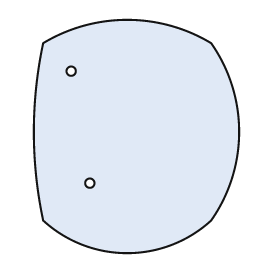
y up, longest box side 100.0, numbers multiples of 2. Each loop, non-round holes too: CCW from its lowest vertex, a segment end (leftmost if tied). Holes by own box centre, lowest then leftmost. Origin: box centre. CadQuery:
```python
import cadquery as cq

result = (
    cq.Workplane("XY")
    .moveTo(-40.0, -36.0)
    .threePointArc((-4.0, -50.0), (32.0, -36.0))
    .threePointArc((44.0, 2.0), (32.0, 40.0))
    .threePointArc((-4.0, 50.0), (-40.0, 40.0))
    .threePointArc((-44.0, 2.0), (-40.0, -36.0))
    .close()
    .moveTo(-20.0, -20.0)
    .circle(2.0)
    .moveTo(-28.0, 28.0)
    .circle(2.0)
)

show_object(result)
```